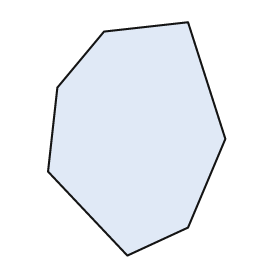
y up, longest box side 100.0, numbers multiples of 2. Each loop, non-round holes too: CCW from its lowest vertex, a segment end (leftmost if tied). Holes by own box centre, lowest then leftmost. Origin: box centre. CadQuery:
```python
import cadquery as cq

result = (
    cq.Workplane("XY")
    .moveTo(-4.0, -50.0)
    .lineTo(22.0, -38.0)
    .lineTo(38.0, 0.0)
    .lineTo(22.0, 50.0)
    .lineTo(-14.0, 46.0)
    .lineTo(-34.0, 22.0)
    .lineTo(-38.0, -14.0)
    .close()
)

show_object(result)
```